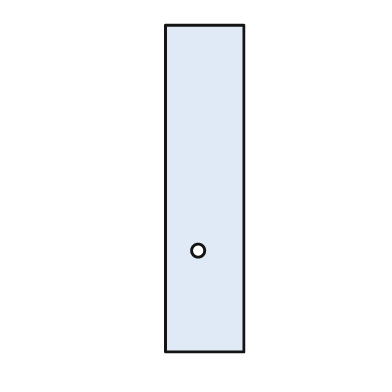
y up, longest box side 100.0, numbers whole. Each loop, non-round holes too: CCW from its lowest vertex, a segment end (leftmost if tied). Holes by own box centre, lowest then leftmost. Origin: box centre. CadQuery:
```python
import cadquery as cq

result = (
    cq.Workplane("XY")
    .moveTo(-12.0, -50.0)
    .lineTo(12.0, -50.0)
    .lineTo(12.0, 50.0)
    .lineTo(-12.0, 50.0)
    .close()
    .moveTo(-2.0, -19.0)
    .circle(2.0)
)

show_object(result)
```